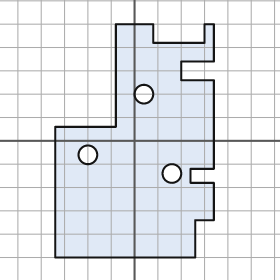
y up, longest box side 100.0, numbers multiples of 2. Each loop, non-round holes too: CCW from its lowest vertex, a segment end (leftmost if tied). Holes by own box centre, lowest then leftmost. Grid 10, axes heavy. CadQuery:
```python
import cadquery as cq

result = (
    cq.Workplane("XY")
    .moveTo(-34.0, -50.0)
    .lineTo(26.0, -50.0)
    .lineTo(26.0, -34.0)
    .lineTo(34.0, -34.0)
    .lineTo(34.0, -18.0)
    .lineTo(24.0, -18.0)
    .lineTo(24.0, -12.0)
    .lineTo(34.0, -12.0)
    .lineTo(34.0, 26.0)
    .lineTo(20.0, 26.0)
    .lineTo(20.0, 34.0)
    .lineTo(34.0, 34.0)
    .lineTo(34.0, 50.0)
    .lineTo(30.0, 50.0)
    .lineTo(30.0, 42.0)
    .lineTo(8.0, 42.0)
    .lineTo(8.0, 50.0)
    .lineTo(-8.0, 50.0)
    .lineTo(-8.0, 6.0)
    .lineTo(-34.0, 6.0)
    .close()
    .moveTo(16.0, -14.0)
    .circle(4.0)
    .moveTo(-20.0, -6.0)
    .circle(4.0)
    .moveTo(4.0, 20.0)
    .circle(4.0)
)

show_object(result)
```